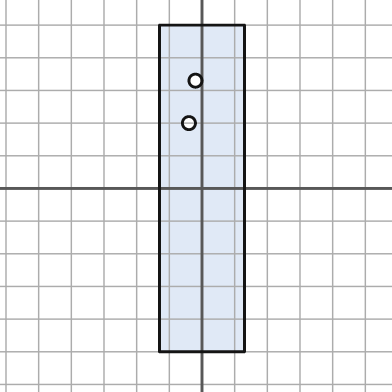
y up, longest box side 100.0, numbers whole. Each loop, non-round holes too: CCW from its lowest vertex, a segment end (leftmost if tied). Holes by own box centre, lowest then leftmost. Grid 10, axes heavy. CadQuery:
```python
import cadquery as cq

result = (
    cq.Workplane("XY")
    .moveTo(-13.0, -50.0)
    .lineTo(13.0, -50.0)
    .lineTo(13.0, 50.0)
    .lineTo(-13.0, 50.0)
    .close()
    .moveTo(-4.0, 20.0)
    .circle(2.0)
    .moveTo(-2.0, 33.0)
    .circle(2.0)
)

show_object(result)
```